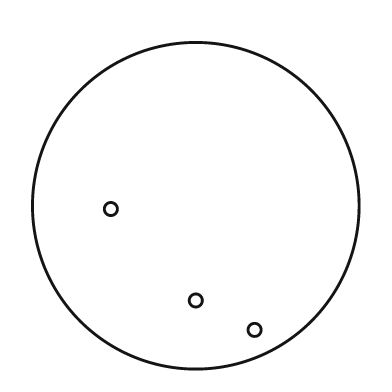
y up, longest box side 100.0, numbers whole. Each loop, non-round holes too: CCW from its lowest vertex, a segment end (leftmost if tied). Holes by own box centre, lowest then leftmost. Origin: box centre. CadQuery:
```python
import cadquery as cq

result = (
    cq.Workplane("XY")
    .moveTo(0.0, 0.0)
    .circle(50.0)
    .moveTo(18.0, -38.0)
    .circle(2.0)
    .moveTo(0.0, -29.0)
    .circle(2.0)
    .moveTo(-26.0, -1.0)
    .circle(2.0)
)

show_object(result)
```